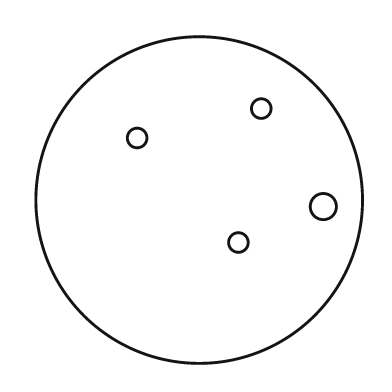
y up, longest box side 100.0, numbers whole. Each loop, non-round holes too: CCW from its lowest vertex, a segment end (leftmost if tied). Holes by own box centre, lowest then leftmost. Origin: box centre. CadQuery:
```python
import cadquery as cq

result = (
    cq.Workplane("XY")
    .moveTo(0.0, 0.0)
    .circle(50.0)
    .moveTo(12.0, -13.0)
    .circle(3.0)
    .moveTo(38.0, -2.0)
    .circle(4.0)
    .moveTo(-19.0, 19.0)
    .circle(3.0)
    .moveTo(19.0, 28.0)
    .circle(3.0)
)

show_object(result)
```